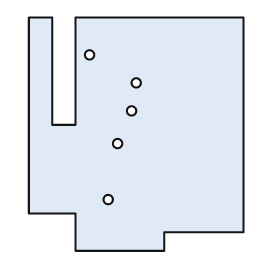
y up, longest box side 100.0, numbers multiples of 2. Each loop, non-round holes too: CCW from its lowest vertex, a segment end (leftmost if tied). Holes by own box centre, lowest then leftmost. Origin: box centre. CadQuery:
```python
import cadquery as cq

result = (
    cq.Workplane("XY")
    .moveTo(-26.0, -50.0)
    .lineTo(12.0, -50.0)
    .lineTo(12.0, -42.0)
    .lineTo(46.0, -42.0)
    .lineTo(46.0, 50.0)
    .lineTo(-26.0, 50.0)
    .lineTo(-26.0, 4.0)
    .lineTo(-36.0, 4.0)
    .lineTo(-36.0, 50.0)
    .lineTo(-46.0, 50.0)
    .lineTo(-46.0, -34.0)
    .lineTo(-26.0, -34.0)
    .close()
    .moveTo(-12.0, -28.0)
    .circle(2.0)
    .moveTo(-8.0, -4.0)
    .circle(2.0)
    .moveTo(-2.0, 10.0)
    .circle(2.0)
    .moveTo(0.0, 22.0)
    .circle(2.0)
    .moveTo(-20.0, 34.0)
    .circle(2.0)
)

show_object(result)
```